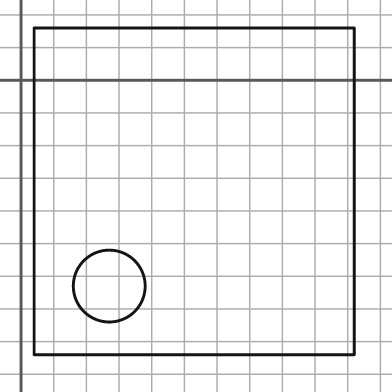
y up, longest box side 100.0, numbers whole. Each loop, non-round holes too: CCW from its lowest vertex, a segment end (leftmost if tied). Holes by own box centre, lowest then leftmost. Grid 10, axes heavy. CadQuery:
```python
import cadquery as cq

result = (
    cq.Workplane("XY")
    .moveTo(4.0, -84.0)
    .lineTo(102.0, -84.0)
    .lineTo(102.0, 16.0)
    .lineTo(4.0, 16.0)
    .close()
    .moveTo(27.0, -63.0)
    .circle(11.0)
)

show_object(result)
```